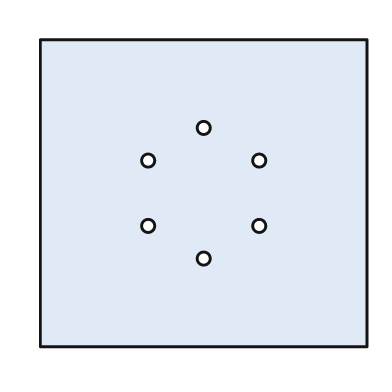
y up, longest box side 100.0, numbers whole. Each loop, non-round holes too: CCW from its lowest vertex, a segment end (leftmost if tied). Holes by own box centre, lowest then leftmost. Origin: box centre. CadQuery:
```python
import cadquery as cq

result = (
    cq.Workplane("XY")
    .moveTo(-50.0, -47.0)
    .lineTo(50.0, -47.0)
    .lineTo(50.0, 47.0)
    .lineTo(-50.0, 47.0)
    .close()
    .moveTo(0.0, -20.0)
    .circle(2.0)
    .moveTo(-17.0, -10.0)
    .circle(2.0)
    .moveTo(17.0, -10.0)
    .circle(2.0)
    .moveTo(-17.0, 10.0)
    .circle(2.0)
    .moveTo(17.0, 10.0)
    .circle(2.0)
    .moveTo(0.0, 20.0)
    .circle(2.0)
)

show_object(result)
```